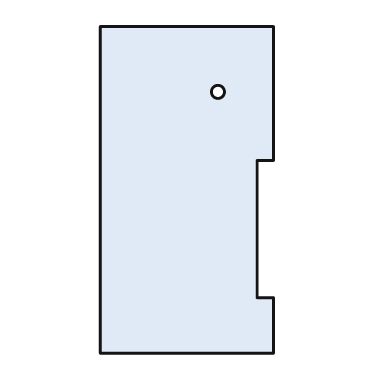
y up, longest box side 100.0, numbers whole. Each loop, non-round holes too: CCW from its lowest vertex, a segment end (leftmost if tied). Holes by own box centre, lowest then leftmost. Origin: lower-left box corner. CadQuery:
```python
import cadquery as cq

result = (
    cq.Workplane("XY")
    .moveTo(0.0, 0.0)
    .lineTo(53.0, 0.0)
    .lineTo(53.0, 17.0)
    .lineTo(48.0, 17.0)
    .lineTo(48.0, 59.0)
    .lineTo(53.0, 59.0)
    .lineTo(53.0, 100.0)
    .lineTo(0.0, 100.0)
    .close()
    .moveTo(36.0, 80.0)
    .circle(2.0)
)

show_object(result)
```